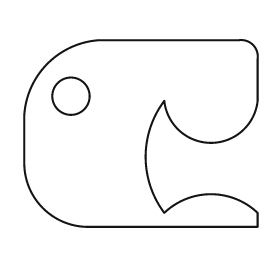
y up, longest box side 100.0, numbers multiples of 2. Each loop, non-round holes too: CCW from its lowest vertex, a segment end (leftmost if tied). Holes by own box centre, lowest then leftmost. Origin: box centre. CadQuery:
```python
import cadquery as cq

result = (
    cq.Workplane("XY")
    .moveTo(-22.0, -40.0)
    .lineTo(50.0, -40.0)
    .lineTo(50.0, -34.0)
    .threePointArc((30.0, -26.0), (10.0, -34.0))
    .threePointArc((2.0, -10.0), (10.0, 14.0))
    .threePointArc((30.0, -4.0), (50.0, 14.0))
    .lineTo(50.0, 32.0)
    .threePointArc((48.0, 38.0), (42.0, 40.0))
    .lineTo(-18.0, 40.0)
    .threePointArc((-40.0, 30.0), (-50.0, 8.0))
    .lineTo(-50.0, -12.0)
    .threePointArc((-42.0, -32.0), (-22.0, -40.0))
    .close()
    .moveTo(-30.0, 16.0)
    .circle(8.0)
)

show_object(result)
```